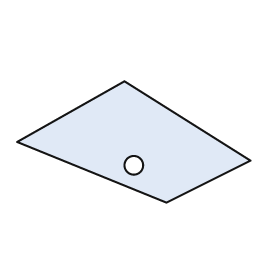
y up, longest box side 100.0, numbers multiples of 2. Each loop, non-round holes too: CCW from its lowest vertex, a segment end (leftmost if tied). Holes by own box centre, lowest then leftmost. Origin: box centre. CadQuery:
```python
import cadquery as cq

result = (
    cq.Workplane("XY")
    .moveTo(14.0, -26.0)
    .lineTo(50.0, -8.0)
    .lineTo(-4.0, 26.0)
    .lineTo(-50.0, 0.0)
    .close()
    .moveTo(0.0, -10.0)
    .circle(4.0)
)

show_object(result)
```